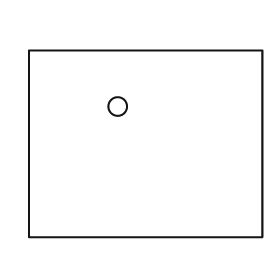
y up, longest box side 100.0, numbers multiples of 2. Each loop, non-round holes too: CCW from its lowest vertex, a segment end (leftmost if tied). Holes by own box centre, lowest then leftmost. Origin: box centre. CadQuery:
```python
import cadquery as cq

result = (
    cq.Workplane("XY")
    .moveTo(-50.0, -40.0)
    .lineTo(50.0, -40.0)
    .lineTo(50.0, 40.0)
    .lineTo(-50.0, 40.0)
    .close()
    .moveTo(-12.0, 16.0)
    .circle(4.0)
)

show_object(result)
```